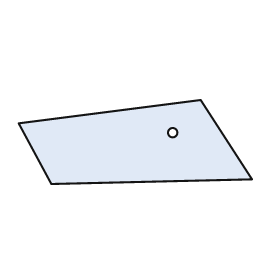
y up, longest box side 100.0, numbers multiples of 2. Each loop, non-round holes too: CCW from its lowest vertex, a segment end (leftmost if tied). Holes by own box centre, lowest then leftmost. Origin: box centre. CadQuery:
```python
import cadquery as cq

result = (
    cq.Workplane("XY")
    .moveTo(-36.0, -18.0)
    .lineTo(50.0, -16.0)
    .lineTo(28.0, 18.0)
    .lineTo(-50.0, 8.0)
    .close()
    .moveTo(16.0, 4.0)
    .circle(2.0)
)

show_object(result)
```